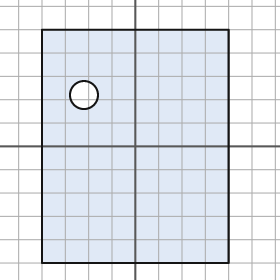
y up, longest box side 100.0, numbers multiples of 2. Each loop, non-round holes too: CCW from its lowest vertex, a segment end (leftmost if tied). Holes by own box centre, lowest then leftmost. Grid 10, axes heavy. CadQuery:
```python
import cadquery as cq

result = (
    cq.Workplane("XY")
    .moveTo(-40.0, -50.0)
    .lineTo(40.0, -50.0)
    .lineTo(40.0, 50.0)
    .lineTo(-40.0, 50.0)
    .close()
    .moveTo(-22.0, 22.0)
    .circle(6.0)
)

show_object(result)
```